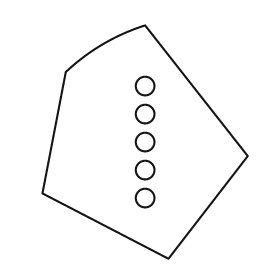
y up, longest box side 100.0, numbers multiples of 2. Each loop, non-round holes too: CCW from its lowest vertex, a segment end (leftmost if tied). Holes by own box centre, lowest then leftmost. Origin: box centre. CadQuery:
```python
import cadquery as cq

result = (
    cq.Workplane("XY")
    .moveTo(10.0, -50.0)
    .lineTo(44.0, -6.0)
    .lineTo(0.0, 50.0)
    .threePointArc((-18.0, 42.0), (-34.0, 30.0))
    .lineTo(-44.0, -22.0)
    .close()
    .moveTo(0.0, -24.0)
    .circle(4.0)
    .moveTo(0.0, -12.0)
    .circle(4.0)
    .moveTo(0.0, 0.0)
    .circle(4.0)
    .moveTo(0.0, 12.0)
    .circle(4.0)
    .moveTo(0.0, 24.0)
    .circle(4.0)
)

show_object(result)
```